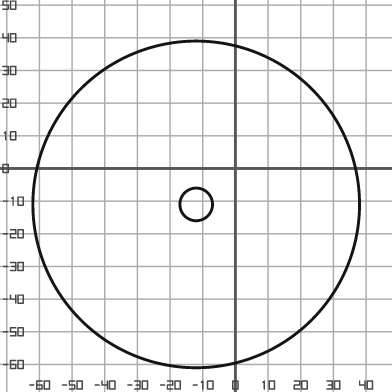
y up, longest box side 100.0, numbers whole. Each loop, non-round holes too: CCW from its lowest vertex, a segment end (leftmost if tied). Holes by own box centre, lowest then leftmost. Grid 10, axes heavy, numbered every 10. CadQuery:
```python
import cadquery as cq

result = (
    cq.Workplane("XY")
    .moveTo(-12.0, -11.0)
    .circle(50.0)
    .moveTo(-12.0, -11.0)
    .circle(5.0)
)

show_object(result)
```